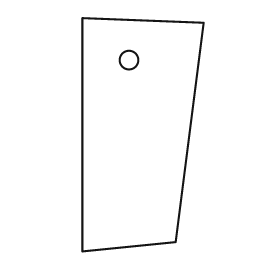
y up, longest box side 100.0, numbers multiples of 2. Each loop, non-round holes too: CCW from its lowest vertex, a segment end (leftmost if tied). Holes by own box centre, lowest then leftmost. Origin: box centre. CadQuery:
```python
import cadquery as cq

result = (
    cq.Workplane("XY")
    .moveTo(-26.0, -50.0)
    .lineTo(14.0, -46.0)
    .lineTo(26.0, 48.0)
    .lineTo(-26.0, 50.0)
    .close()
    .moveTo(-6.0, 32.0)
    .circle(4.0)
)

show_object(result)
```